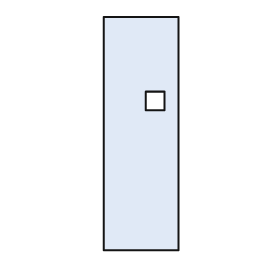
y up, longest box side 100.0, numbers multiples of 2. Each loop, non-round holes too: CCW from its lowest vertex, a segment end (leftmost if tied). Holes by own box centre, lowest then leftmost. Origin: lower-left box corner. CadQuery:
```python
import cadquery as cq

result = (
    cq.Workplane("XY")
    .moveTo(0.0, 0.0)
    .lineTo(32.0, 0.0)
    .lineTo(32.0, 100.0)
    .lineTo(0.0, 100.0)
    .close()
    .moveTo(18.0, 60.0)
    .lineTo(26.0, 60.0)
    .lineTo(26.0, 68.0)
    .lineTo(18.0, 68.0)
    .close()
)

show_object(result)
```